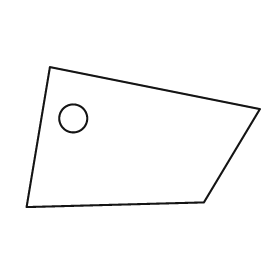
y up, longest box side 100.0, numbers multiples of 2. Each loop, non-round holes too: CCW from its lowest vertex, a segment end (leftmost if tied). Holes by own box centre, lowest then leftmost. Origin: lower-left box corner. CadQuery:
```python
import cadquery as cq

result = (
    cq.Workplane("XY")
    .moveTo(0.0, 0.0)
    .lineTo(76.0, 2.0)
    .lineTo(100.0, 42.0)
    .lineTo(10.0, 60.0)
    .close()
    .moveTo(20.0, 38.0)
    .circle(6.0)
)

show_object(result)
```